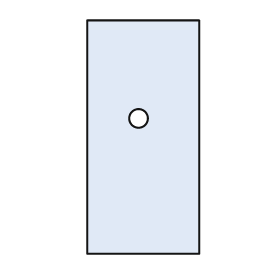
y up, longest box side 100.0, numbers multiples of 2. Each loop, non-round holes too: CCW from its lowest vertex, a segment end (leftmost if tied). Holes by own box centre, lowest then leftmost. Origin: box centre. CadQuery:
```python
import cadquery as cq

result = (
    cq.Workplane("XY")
    .moveTo(-24.0, -50.0)
    .lineTo(24.0, -50.0)
    .lineTo(24.0, 50.0)
    .lineTo(-24.0, 50.0)
    .close()
    .moveTo(-2.0, 8.0)
    .circle(4.0)
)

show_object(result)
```